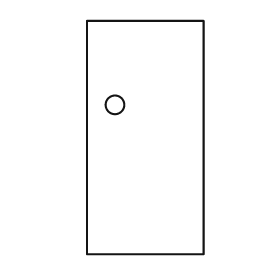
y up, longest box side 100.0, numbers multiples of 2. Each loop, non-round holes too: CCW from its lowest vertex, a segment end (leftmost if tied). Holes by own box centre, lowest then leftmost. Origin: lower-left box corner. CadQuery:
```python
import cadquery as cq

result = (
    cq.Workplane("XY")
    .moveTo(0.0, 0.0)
    .lineTo(50.0, 0.0)
    .lineTo(50.0, 100.0)
    .lineTo(0.0, 100.0)
    .close()
    .moveTo(12.0, 64.0)
    .circle(4.0)
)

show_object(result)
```